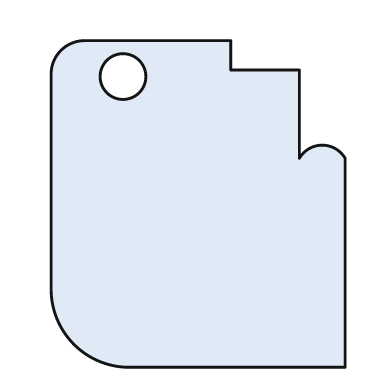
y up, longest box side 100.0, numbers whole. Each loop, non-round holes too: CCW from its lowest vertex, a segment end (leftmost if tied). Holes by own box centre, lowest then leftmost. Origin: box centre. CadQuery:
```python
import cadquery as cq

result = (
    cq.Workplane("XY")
    .moveTo(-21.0, -50.0)
    .lineTo(45.0, -50.0)
    .lineTo(45.0, 14.0)
    .threePointArc((38.0, 18.0), (31.0, 14.0))
    .lineTo(31.0, 41.0)
    .lineTo(10.0, 41.0)
    .lineTo(10.0, 50.0)
    .lineTo(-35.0, 50.0)
    .threePointArc((-42.0, 47.0), (-45.0, 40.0))
    .lineTo(-45.0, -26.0)
    .threePointArc((-38.0, -43.0), (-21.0, -50.0))
    .close()
    .moveTo(-23.0, 39.0)
    .circle(7.0)
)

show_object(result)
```